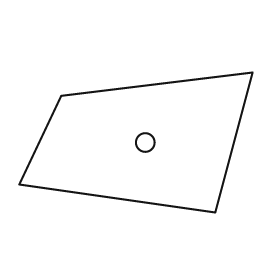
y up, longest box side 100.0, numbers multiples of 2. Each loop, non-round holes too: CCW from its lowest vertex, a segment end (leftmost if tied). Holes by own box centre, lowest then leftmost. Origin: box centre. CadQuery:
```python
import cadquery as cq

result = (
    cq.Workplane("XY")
    .moveTo(34.0, -30.0)
    .lineTo(50.0, 30.0)
    .lineTo(-32.0, 20.0)
    .lineTo(-50.0, -18.0)
    .close()
    .moveTo(4.0, 0.0)
    .circle(4.0)
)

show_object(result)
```